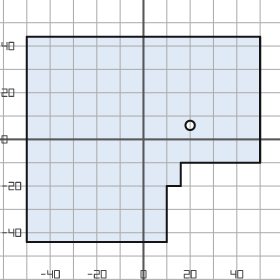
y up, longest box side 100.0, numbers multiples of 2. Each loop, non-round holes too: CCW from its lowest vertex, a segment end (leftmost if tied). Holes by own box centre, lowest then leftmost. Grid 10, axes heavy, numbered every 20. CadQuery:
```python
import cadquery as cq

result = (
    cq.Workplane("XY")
    .moveTo(-50.0, -44.0)
    .lineTo(10.0, -44.0)
    .lineTo(10.0, -20.0)
    .lineTo(16.0, -20.0)
    .lineTo(16.0, -10.0)
    .lineTo(50.0, -10.0)
    .lineTo(50.0, 44.0)
    .lineTo(-50.0, 44.0)
    .close()
    .moveTo(20.0, 6.0)
    .circle(2.0)
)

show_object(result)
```